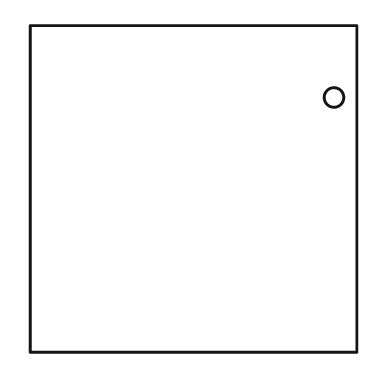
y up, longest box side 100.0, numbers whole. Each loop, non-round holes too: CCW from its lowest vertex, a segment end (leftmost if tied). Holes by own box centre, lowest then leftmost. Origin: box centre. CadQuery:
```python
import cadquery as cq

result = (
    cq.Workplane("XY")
    .moveTo(-50.0, -50.0)
    .lineTo(50.0, -50.0)
    .lineTo(50.0, 50.0)
    .lineTo(-50.0, 50.0)
    .close()
    .moveTo(43.0, 28.0)
    .circle(3.0)
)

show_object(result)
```